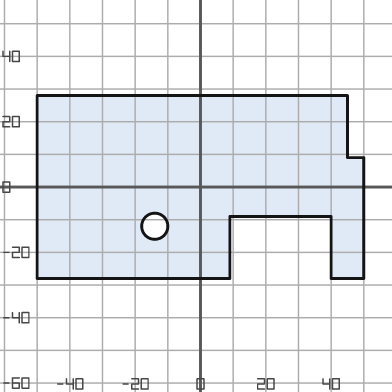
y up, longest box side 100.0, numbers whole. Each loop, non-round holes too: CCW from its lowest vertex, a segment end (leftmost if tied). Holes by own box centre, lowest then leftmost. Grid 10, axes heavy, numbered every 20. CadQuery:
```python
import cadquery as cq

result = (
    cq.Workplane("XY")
    .moveTo(-50.0, -28.0)
    .lineTo(9.0, -28.0)
    .lineTo(9.0, -9.0)
    .lineTo(40.0, -9.0)
    .lineTo(40.0, -28.0)
    .lineTo(50.0, -28.0)
    .lineTo(50.0, 9.0)
    .lineTo(45.0, 9.0)
    .lineTo(45.0, 28.0)
    .lineTo(-50.0, 28.0)
    .close()
    .moveTo(-14.0, -12.0)
    .circle(4.0)
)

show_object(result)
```